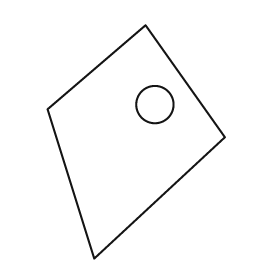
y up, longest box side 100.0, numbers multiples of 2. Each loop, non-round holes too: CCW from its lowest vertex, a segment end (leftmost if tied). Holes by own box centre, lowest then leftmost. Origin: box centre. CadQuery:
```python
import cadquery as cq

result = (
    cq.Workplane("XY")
    .moveTo(-18.0, -50.0)
    .lineTo(38.0, 2.0)
    .lineTo(4.0, 50.0)
    .lineTo(-38.0, 14.0)
    .close()
    .moveTo(8.0, 16.0)
    .circle(8.0)
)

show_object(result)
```